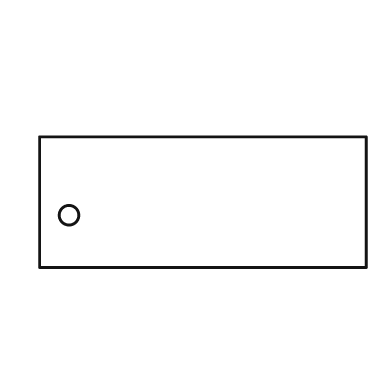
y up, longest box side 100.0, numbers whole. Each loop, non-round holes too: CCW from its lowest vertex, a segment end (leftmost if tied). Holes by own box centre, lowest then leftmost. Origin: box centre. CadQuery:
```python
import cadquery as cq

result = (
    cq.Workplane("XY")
    .moveTo(-50.0, -20.0)
    .lineTo(50.0, -20.0)
    .lineTo(50.0, 20.0)
    .lineTo(-50.0, 20.0)
    .close()
    .moveTo(-41.0, -4.0)
    .circle(3.0)
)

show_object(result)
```